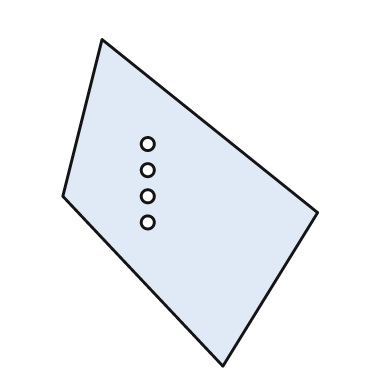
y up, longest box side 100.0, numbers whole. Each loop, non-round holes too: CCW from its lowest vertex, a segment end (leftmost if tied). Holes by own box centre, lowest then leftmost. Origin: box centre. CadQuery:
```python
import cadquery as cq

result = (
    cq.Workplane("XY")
    .moveTo(10.0, -50.0)
    .lineTo(39.0, -3.0)
    .lineTo(-27.0, 50.0)
    .lineTo(-39.0, 2.0)
    .close()
    .moveTo(-13.0, -6.0)
    .circle(2.0)
    .moveTo(-13.0, 2.0)
    .circle(2.0)
    .moveTo(-13.0, 10.0)
    .circle(2.0)
    .moveTo(-13.0, 18.0)
    .circle(2.0)
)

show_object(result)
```